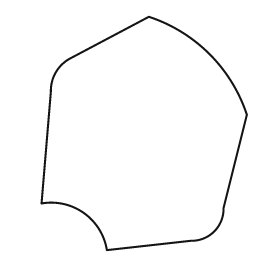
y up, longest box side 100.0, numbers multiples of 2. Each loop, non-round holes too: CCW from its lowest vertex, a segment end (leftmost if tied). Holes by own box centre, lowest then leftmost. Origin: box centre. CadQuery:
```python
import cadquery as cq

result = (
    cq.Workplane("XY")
    .moveTo(-16.0, -50.0)
    .lineTo(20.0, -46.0)
    .threePointArc((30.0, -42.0), (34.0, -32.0))
    .lineTo(44.0, 8.0)
    .threePointArc((28.0, 34.0), (2.0, 50.0))
    .lineTo(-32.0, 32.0)
    .threePointArc((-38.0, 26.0), (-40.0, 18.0))
    .lineTo(-44.0, -30.0)
    .threePointArc((-26.0, -34.0), (-16.0, -50.0))
    .close()
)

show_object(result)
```